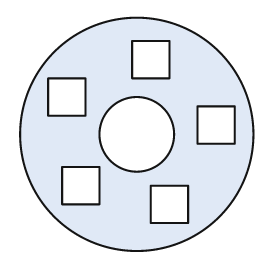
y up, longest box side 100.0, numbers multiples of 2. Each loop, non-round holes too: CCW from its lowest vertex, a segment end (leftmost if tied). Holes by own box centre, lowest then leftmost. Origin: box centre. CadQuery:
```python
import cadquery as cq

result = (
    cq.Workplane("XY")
    .moveTo(0.0, 0.0)
    .circle(50.0)
    .moveTo(6.0, -38.0)
    .lineTo(22.0, -38.0)
    .lineTo(22.0, -22.0)
    .lineTo(6.0, -22.0)
    .close()
    .moveTo(-32.0, -30.0)
    .lineTo(-16.0, -30.0)
    .lineTo(-16.0, -14.0)
    .lineTo(-32.0, -14.0)
    .close()
    .moveTo(0.0, 0.0)
    .circle(16.0)
    .moveTo(26.0, -4.0)
    .lineTo(42.0, -4.0)
    .lineTo(42.0, 12.0)
    .lineTo(26.0, 12.0)
    .close()
    .moveTo(-38.0, 8.0)
    .lineTo(-22.0, 8.0)
    .lineTo(-22.0, 24.0)
    .lineTo(-38.0, 24.0)
    .close()
    .moveTo(-2.0, 24.0)
    .lineTo(14.0, 24.0)
    .lineTo(14.0, 40.0)
    .lineTo(-2.0, 40.0)
    .close()
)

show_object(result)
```